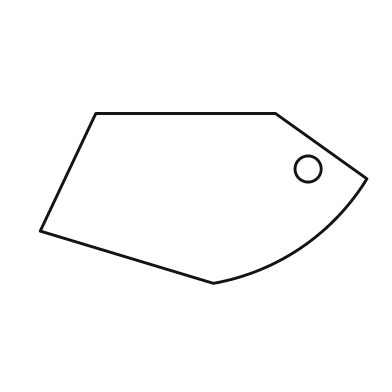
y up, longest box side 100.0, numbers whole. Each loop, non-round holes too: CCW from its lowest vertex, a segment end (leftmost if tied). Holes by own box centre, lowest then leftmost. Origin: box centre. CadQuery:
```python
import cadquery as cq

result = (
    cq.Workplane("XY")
    .moveTo(3.0, -26.0)
    .threePointArc((30.0, -15.0), (50.0, 6.0))
    .lineTo(22.0, 26.0)
    .lineTo(-33.0, 26.0)
    .lineTo(-50.0, -10.0)
    .close()
    .moveTo(32.0, 9.0)
    .circle(4.0)
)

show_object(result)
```